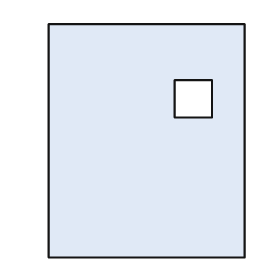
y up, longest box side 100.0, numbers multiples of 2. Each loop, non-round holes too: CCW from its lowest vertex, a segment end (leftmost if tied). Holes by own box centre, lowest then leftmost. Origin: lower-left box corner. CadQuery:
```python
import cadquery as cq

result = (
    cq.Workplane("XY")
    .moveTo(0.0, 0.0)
    .lineTo(84.0, 0.0)
    .lineTo(84.0, 100.0)
    .lineTo(0.0, 100.0)
    .close()
    .moveTo(54.0, 60.0)
    .lineTo(70.0, 60.0)
    .lineTo(70.0, 76.0)
    .lineTo(54.0, 76.0)
    .close()
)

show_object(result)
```